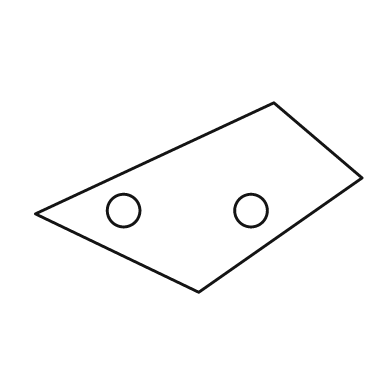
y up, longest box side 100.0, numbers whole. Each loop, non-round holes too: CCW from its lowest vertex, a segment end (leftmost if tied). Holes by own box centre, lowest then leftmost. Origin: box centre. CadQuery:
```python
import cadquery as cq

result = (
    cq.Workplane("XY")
    .moveTo(0.0, -29.0)
    .lineTo(50.0, 6.0)
    .lineTo(23.0, 29.0)
    .lineTo(-50.0, -5.0)
    .close()
    .moveTo(-23.0, -4.0)
    .circle(5.0)
    .moveTo(16.0, -4.0)
    .circle(5.0)
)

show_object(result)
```